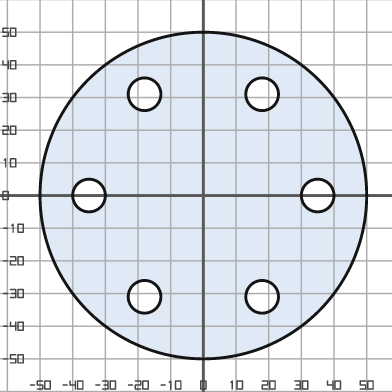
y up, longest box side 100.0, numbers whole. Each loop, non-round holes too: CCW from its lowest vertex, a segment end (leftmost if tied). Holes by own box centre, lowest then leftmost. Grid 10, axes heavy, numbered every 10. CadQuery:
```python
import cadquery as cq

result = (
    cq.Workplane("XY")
    .moveTo(0.0, 0.0)
    .circle(50.0)
    .moveTo(-18.0, -31.0)
    .circle(5.0)
    .moveTo(18.0, -31.0)
    .circle(5.0)
    .moveTo(-35.0, 0.0)
    .circle(5.0)
    .moveTo(35.0, 0.0)
    .circle(5.0)
    .moveTo(-18.0, 31.0)
    .circle(5.0)
    .moveTo(18.0, 31.0)
    .circle(5.0)
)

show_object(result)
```